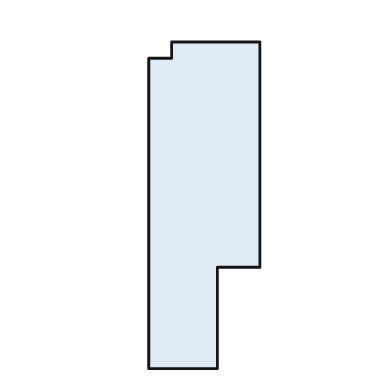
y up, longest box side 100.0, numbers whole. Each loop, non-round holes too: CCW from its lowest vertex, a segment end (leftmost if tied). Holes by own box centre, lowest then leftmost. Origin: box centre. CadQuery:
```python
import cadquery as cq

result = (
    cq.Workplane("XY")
    .moveTo(-17.0, -50.0)
    .lineTo(4.0, -50.0)
    .lineTo(4.0, -19.0)
    .lineTo(17.0, -19.0)
    .lineTo(17.0, 50.0)
    .lineTo(-10.0, 50.0)
    .lineTo(-10.0, 45.0)
    .lineTo(-17.0, 45.0)
    .close()
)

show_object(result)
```